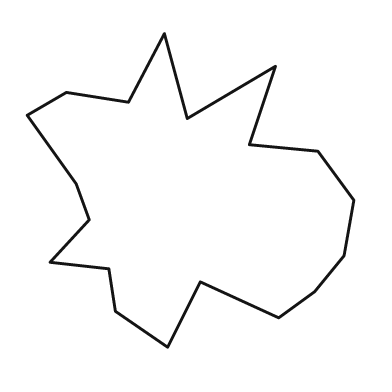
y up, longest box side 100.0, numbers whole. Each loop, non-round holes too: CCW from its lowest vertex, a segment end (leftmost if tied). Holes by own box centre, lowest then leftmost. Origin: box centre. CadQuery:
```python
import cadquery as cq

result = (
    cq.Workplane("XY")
    .moveTo(-7.0, -48.0)
    .lineTo(3.0, -28.0)
    .lineTo(27.0, -39.0)
    .lineTo(38.0, -31.0)
    .lineTo(47.0, -20.0)
    .lineTo(50.0, -3.0)
    .lineTo(39.0, 12.0)
    .lineTo(18.0, 14.0)
    .lineTo(26.0, 38.0)
    .lineTo(-1.0, 22.0)
    .lineTo(-8.0, 48.0)
    .lineTo(-19.0, 27.0)
    .lineTo(-38.0, 30.0)
    .lineTo(-50.0, 23.0)
    .lineTo(-35.0, 2.0)
    .lineTo(-31.0, -9.0)
    .lineTo(-43.0, -22.0)
    .lineTo(-25.0, -24.0)
    .lineTo(-23.0, -37.0)
    .close()
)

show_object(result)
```